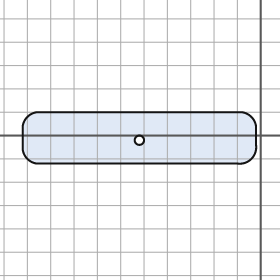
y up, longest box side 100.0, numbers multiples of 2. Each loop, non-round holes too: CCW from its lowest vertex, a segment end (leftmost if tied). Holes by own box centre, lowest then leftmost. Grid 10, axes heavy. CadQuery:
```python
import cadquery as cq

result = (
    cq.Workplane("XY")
    .moveTo(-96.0, -12.0)
    .lineTo(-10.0, -12.0)
    .threePointArc((-4.0, -10.0), (-2.0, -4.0))
    .lineTo(-2.0, 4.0)
    .threePointArc((-4.0, 8.0), (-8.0, 10.0))
    .lineTo(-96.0, 10.0)
    .threePointArc((-100.0, 8.0), (-102.0, 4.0))
    .lineTo(-102.0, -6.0)
    .threePointArc((-100.0, -10.0), (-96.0, -12.0))
    .close()
    .moveTo(-52.0, -2.0)
    .circle(2.0)
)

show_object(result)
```